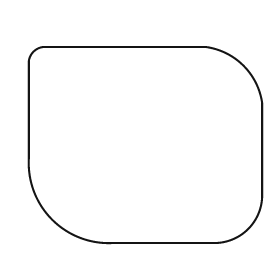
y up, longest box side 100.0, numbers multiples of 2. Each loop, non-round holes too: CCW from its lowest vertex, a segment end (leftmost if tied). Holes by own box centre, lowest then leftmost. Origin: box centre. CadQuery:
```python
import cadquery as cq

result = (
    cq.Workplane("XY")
    .moveTo(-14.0, -42.0)
    .lineTo(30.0, -42.0)
    .threePointArc((44.0, -36.0), (50.0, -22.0))
    .lineTo(50.0, 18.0)
    .threePointArc((42.0, 34.0), (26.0, 42.0))
    .lineTo(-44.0, 42.0)
    .threePointArc((-48.0, 40.0), (-50.0, 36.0))
    .lineTo(-50.0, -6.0)
    .threePointArc((-40.0, -32.0), (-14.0, -42.0))
    .close()
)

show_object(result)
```